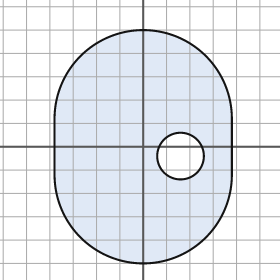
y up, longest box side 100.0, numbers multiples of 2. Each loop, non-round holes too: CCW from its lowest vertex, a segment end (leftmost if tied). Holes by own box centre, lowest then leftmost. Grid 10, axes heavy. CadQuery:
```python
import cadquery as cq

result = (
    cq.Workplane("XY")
    .moveTo(-38.0, -12.0)
    .threePointArc((0.0, -50.0), (38.0, -12.0))
    .lineTo(38.0, 12.0)
    .threePointArc((0.0, 50.0), (-38.0, 12.0))
    .close()
    .moveTo(16.0, -4.0)
    .circle(10.0)
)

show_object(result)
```